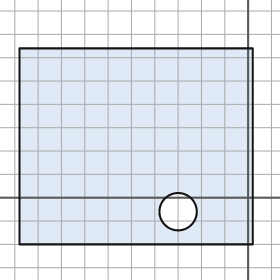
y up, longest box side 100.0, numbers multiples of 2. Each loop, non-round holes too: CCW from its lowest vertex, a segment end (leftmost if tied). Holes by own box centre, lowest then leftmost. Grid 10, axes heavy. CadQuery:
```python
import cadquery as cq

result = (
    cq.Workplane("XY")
    .moveTo(-98.0, -20.0)
    .lineTo(2.0, -20.0)
    .lineTo(2.0, 64.0)
    .lineTo(-98.0, 64.0)
    .close()
    .moveTo(-30.0, -6.0)
    .circle(8.0)
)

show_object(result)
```